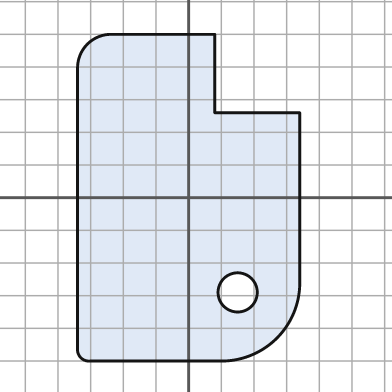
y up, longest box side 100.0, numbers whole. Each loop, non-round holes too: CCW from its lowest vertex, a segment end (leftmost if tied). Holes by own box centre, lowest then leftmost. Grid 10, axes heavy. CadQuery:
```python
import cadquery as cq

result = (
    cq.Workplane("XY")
    .moveTo(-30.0, -50.0)
    .lineTo(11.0, -50.0)
    .threePointArc((27.0, -43.0), (34.0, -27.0))
    .lineTo(34.0, 26.0)
    .lineTo(8.0, 26.0)
    .lineTo(8.0, 50.0)
    .lineTo(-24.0, 50.0)
    .threePointArc((-31.0, 47.0), (-34.0, 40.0))
    .lineTo(-34.0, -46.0)
    .threePointArc((-33.0, -49.0), (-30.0, -50.0))
    .close()
    .moveTo(15.0, -29.0)
    .circle(6.0)
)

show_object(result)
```